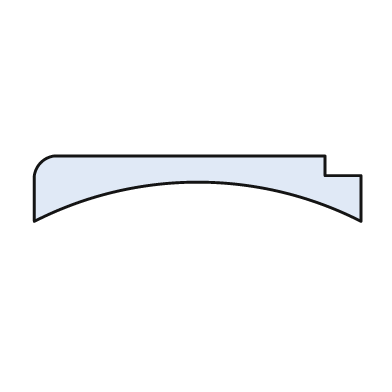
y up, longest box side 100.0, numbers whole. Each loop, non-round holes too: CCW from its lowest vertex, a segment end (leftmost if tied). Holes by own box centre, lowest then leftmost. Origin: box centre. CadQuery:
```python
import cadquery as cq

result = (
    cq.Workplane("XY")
    .moveTo(-50.0, -10.0)
    .threePointArc((0.0, 2.0), (50.0, -10.0))
    .lineTo(50.0, 4.0)
    .lineTo(39.0, 4.0)
    .lineTo(39.0, 10.0)
    .lineTo(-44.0, 10.0)
    .threePointArc((-48.0, 8.0), (-50.0, 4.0))
    .close()
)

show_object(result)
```